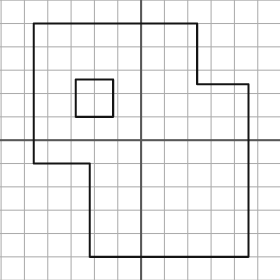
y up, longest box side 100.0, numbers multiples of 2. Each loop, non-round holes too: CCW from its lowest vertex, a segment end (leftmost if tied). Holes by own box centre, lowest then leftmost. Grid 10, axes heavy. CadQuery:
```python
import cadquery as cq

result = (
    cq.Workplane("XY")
    .moveTo(-22.0, -50.0)
    .lineTo(46.0, -50.0)
    .lineTo(46.0, 24.0)
    .lineTo(24.0, 24.0)
    .lineTo(24.0, 50.0)
    .lineTo(-46.0, 50.0)
    .lineTo(-46.0, -10.0)
    .lineTo(-22.0, -10.0)
    .close()
    .moveTo(-28.0, 10.0)
    .lineTo(-12.0, 10.0)
    .lineTo(-12.0, 26.0)
    .lineTo(-28.0, 26.0)
    .close()
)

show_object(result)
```